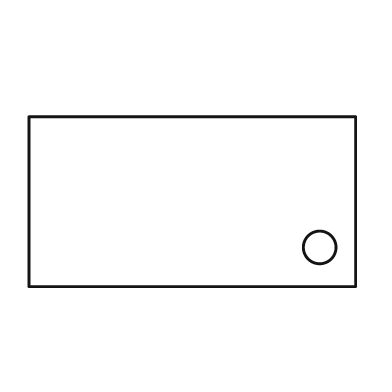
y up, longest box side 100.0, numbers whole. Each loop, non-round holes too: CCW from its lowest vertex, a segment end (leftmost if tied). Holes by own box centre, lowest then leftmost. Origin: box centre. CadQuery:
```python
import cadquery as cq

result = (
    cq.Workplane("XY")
    .moveTo(-50.0, -26.0)
    .lineTo(50.0, -26.0)
    .lineTo(50.0, 26.0)
    .lineTo(-50.0, 26.0)
    .close()
    .moveTo(39.0, -14.0)
    .circle(5.0)
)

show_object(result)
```